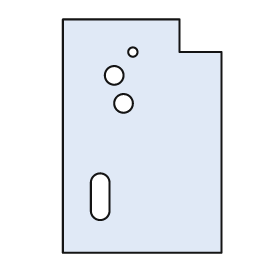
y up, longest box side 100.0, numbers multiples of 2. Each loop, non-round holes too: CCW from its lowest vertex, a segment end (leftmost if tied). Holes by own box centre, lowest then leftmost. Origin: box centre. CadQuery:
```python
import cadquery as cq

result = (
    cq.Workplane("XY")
    .moveTo(-34.0, -50.0)
    .lineTo(34.0, -50.0)
    .lineTo(34.0, 36.0)
    .lineTo(16.0, 36.0)
    .lineTo(16.0, 50.0)
    .lineTo(-34.0, 50.0)
    .close()
    .moveTo(-22.0, -32.0)
    .threePointArc((-18.0, -36.0), (-14.0, -32.0))
    .lineTo(-14.0, -20.0)
    .threePointArc((-18.0, -16.0), (-22.0, -20.0))
    .close()
    .moveTo(-8.0, 14.0)
    .circle(4.0)
    .moveTo(-12.0, 26.0)
    .circle(4.0)
    .moveTo(-4.0, 36.0)
    .circle(2.0)
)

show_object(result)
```